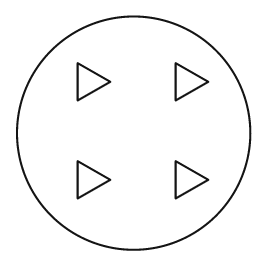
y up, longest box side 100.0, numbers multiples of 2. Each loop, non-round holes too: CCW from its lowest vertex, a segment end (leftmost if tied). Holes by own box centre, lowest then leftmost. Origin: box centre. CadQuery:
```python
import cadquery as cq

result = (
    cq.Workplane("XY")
    .moveTo(0.0, 0.0)
    .circle(50.0)
    .moveTo(-24.0, -28.0)
    .lineTo(-10.0, -20.0)
    .lineTo(-24.0, -12.0)
    .close()
    .moveTo(18.0, -28.0)
    .lineTo(32.0, -20.0)
    .lineTo(18.0, -12.0)
    .close()
    .moveTo(-24.0, 14.0)
    .lineTo(-10.0, 22.0)
    .lineTo(-24.0, 30.0)
    .close()
    .moveTo(18.0, 14.0)
    .lineTo(32.0, 22.0)
    .lineTo(18.0, 30.0)
    .close()
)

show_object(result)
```